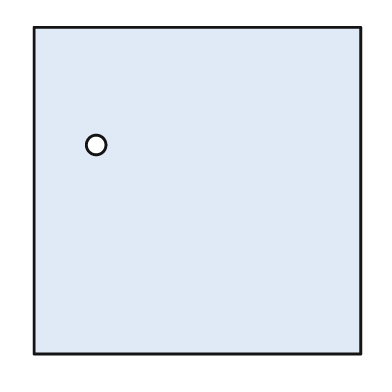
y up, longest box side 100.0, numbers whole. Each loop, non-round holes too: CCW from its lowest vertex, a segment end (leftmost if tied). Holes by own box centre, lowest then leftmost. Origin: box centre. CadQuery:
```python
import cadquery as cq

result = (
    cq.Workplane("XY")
    .moveTo(-50.0, -50.0)
    .lineTo(50.0, -50.0)
    .lineTo(50.0, 50.0)
    .lineTo(-50.0, 50.0)
    .close()
    .moveTo(-31.0, 14.0)
    .circle(3.0)
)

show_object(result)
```